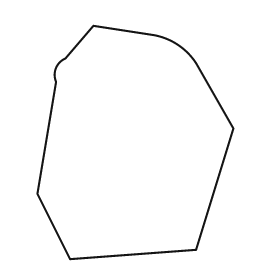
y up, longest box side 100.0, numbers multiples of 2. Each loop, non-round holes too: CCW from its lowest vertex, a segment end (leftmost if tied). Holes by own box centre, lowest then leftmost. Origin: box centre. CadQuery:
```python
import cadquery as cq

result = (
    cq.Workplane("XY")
    .moveTo(-28.0, -50.0)
    .lineTo(26.0, -46.0)
    .lineTo(42.0, 6.0)
    .lineTo(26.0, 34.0)
    .threePointArc((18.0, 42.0), (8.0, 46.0))
    .lineTo(-18.0, 50.0)
    .lineTo(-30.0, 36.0)
    .threePointArc((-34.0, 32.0), (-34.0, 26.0))
    .lineTo(-42.0, -22.0)
    .close()
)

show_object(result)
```